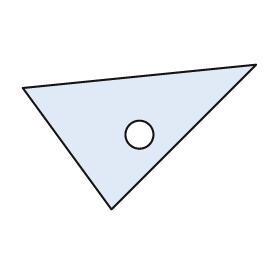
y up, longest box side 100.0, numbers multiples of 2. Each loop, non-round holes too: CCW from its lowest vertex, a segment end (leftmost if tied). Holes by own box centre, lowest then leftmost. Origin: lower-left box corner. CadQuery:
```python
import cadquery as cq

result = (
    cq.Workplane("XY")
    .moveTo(38.0, 0.0)
    .lineTo(100.0, 62.0)
    .lineTo(0.0, 52.0)
    .close()
    .moveTo(50.0, 32.0)
    .circle(6.0)
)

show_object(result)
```